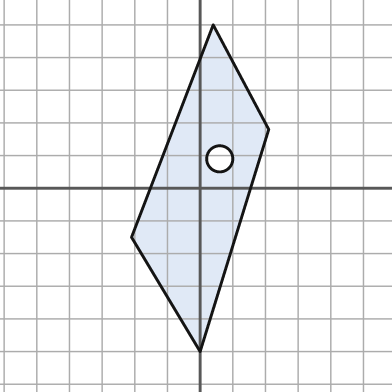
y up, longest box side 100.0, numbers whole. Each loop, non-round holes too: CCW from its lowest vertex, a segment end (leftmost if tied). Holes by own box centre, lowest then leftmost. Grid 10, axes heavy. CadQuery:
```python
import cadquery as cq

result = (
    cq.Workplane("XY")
    .moveTo(0.0, -50.0)
    .lineTo(21.0, 18.0)
    .lineTo(4.0, 50.0)
    .lineTo(-21.0, -15.0)
    .close()
    .moveTo(6.0, 9.0)
    .circle(4.0)
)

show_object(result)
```